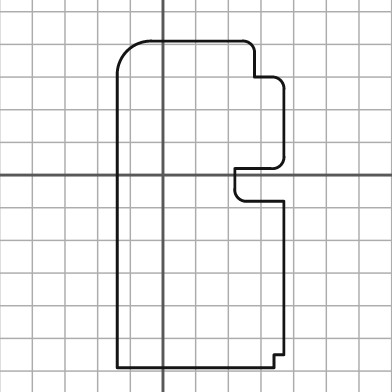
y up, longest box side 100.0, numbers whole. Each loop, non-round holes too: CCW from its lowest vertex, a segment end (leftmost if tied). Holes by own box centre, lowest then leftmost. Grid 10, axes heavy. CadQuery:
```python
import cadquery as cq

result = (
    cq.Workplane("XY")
    .moveTo(-14.0, -59.0)
    .lineTo(34.0, -59.0)
    .lineTo(34.0, -55.0)
    .lineTo(37.0, -55.0)
    .lineTo(37.0, -8.0)
    .lineTo(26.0, -8.0)
    .threePointArc((23.0, -7.0), (22.0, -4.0))
    .lineTo(22.0, 2.0)
    .lineTo(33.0, 2.0)
    .threePointArc((36.0, 3.0), (37.0, 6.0))
    .lineTo(37.0, 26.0)
    .threePointArc((36.0, 29.0), (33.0, 30.0))
    .lineTo(28.0, 30.0)
    .lineTo(28.0, 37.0)
    .threePointArc((27.0, 40.0), (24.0, 41.0))
    .lineTo(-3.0, 41.0)
    .threePointArc((-11.0, 38.0), (-14.0, 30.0))
    .close()
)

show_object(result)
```